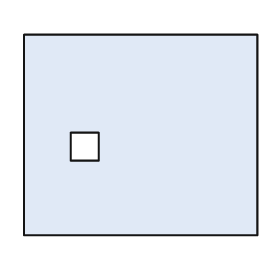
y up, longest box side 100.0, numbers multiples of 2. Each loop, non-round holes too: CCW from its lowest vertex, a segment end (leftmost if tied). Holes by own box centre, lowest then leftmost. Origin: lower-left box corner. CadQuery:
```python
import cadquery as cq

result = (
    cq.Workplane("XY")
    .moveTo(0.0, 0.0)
    .lineTo(100.0, 0.0)
    .lineTo(100.0, 86.0)
    .lineTo(0.0, 86.0)
    .close()
    .moveTo(20.0, 32.0)
    .lineTo(32.0, 32.0)
    .lineTo(32.0, 44.0)
    .lineTo(20.0, 44.0)
    .close()
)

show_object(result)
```